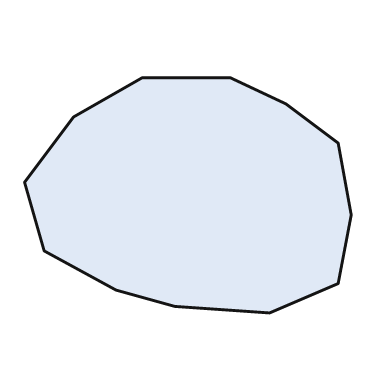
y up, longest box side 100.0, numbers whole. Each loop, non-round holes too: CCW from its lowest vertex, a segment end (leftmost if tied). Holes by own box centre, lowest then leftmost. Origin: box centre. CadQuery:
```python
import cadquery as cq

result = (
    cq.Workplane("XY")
    .moveTo(25.0, -36.0)
    .lineTo(46.0, -27.0)
    .lineTo(50.0, -6.0)
    .lineTo(46.0, 16.0)
    .lineTo(30.0, 28.0)
    .lineTo(13.0, 36.0)
    .lineTo(-14.0, 36.0)
    .lineTo(-35.0, 24.0)
    .lineTo(-50.0, 4.0)
    .lineTo(-44.0, -17.0)
    .lineTo(-22.0, -29.0)
    .lineTo(-4.0, -34.0)
    .close()
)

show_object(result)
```